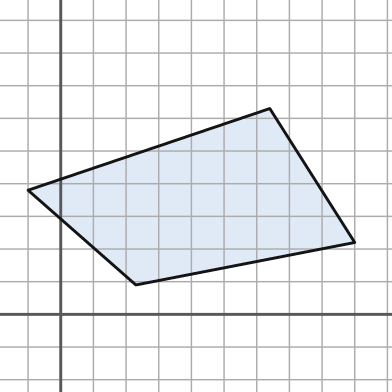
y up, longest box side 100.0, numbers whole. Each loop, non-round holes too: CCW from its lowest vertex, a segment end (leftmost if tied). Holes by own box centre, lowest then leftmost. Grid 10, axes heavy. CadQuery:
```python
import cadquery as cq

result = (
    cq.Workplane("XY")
    .moveTo(23.0, 9.0)
    .lineTo(90.0, 22.0)
    .lineTo(64.0, 63.0)
    .lineTo(-10.0, 38.0)
    .close()
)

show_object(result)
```